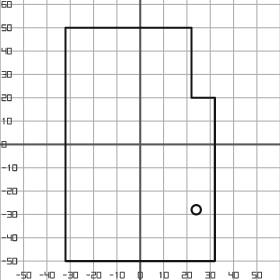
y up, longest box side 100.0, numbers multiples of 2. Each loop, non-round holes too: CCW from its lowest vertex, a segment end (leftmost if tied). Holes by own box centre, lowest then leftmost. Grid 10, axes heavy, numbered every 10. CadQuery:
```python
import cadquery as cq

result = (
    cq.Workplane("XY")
    .moveTo(-32.0, -50.0)
    .lineTo(32.0, -50.0)
    .lineTo(32.0, 20.0)
    .lineTo(22.0, 20.0)
    .lineTo(22.0, 50.0)
    .lineTo(-32.0, 50.0)
    .close()
    .moveTo(24.0, -28.0)
    .circle(2.0)
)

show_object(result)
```